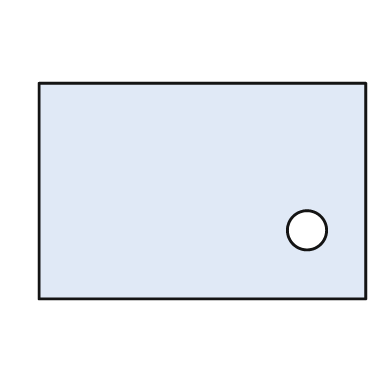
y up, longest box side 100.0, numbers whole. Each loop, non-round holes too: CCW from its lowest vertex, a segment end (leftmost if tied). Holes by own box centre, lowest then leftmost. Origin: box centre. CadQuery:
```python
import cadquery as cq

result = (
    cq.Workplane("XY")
    .moveTo(-50.0, -33.0)
    .lineTo(50.0, -33.0)
    .lineTo(50.0, 33.0)
    .lineTo(-50.0, 33.0)
    .close()
    .moveTo(32.0, -12.0)
    .circle(6.0)
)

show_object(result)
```